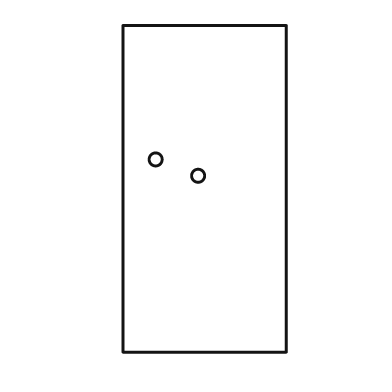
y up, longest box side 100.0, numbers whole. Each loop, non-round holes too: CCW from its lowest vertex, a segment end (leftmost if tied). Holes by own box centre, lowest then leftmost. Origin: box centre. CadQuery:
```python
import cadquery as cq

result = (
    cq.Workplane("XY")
    .moveTo(-25.0, -50.0)
    .lineTo(25.0, -50.0)
    .lineTo(25.0, 50.0)
    .lineTo(-25.0, 50.0)
    .close()
    .moveTo(-2.0, 4.0)
    .circle(2.0)
    .moveTo(-15.0, 9.0)
    .circle(2.0)
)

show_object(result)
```